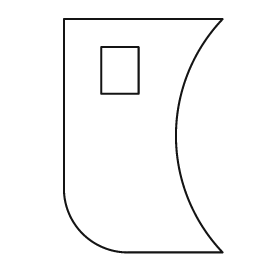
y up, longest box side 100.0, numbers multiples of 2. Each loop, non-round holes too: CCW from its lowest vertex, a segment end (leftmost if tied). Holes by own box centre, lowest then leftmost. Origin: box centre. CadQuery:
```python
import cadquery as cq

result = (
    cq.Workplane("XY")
    .moveTo(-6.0, -50.0)
    .lineTo(34.0, -50.0)
    .threePointArc((14.0, 0.0), (34.0, 50.0))
    .lineTo(-34.0, 50.0)
    .lineTo(-34.0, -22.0)
    .threePointArc((-26.0, -42.0), (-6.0, -50.0))
    .close()
    .moveTo(-18.0, 18.0)
    .lineTo(-2.0, 18.0)
    .lineTo(-2.0, 38.0)
    .lineTo(-18.0, 38.0)
    .close()
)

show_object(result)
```